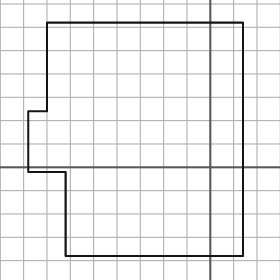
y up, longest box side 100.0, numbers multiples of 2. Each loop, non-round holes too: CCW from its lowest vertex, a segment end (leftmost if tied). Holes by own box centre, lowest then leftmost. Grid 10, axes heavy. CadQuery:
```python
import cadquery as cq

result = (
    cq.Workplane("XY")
    .moveTo(-62.0, -38.0)
    .lineTo(14.0, -38.0)
    .lineTo(14.0, 62.0)
    .lineTo(-70.0, 62.0)
    .lineTo(-70.0, 24.0)
    .lineTo(-78.0, 24.0)
    .lineTo(-78.0, -2.0)
    .lineTo(-62.0, -2.0)
    .close()
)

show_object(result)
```